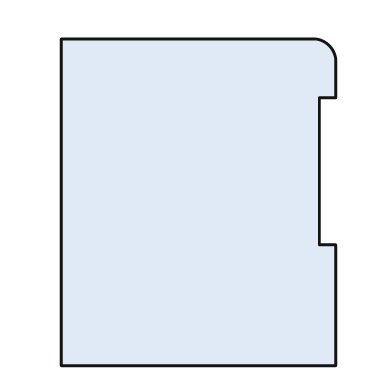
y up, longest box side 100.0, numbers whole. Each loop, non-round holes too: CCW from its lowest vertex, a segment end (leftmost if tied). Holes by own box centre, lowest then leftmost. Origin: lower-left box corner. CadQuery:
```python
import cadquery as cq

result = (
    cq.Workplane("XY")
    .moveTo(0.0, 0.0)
    .lineTo(84.0, 0.0)
    .lineTo(84.0, 37.0)
    .lineTo(79.0, 37.0)
    .lineTo(79.0, 82.0)
    .lineTo(84.0, 82.0)
    .lineTo(84.0, 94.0)
    .threePointArc((82.0, 98.0), (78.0, 100.0))
    .lineTo(0.0, 100.0)
    .close()
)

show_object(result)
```